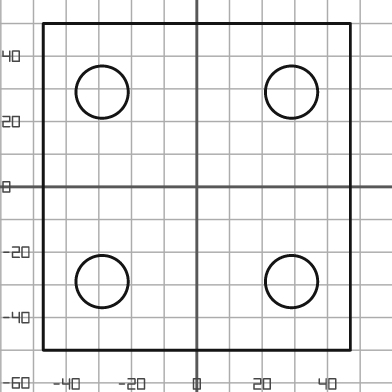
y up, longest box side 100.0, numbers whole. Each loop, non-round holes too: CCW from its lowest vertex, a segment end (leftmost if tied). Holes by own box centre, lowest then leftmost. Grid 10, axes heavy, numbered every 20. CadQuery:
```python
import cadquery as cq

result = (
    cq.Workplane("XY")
    .moveTo(-47.0, -50.0)
    .lineTo(47.0, -50.0)
    .lineTo(47.0, 50.0)
    .lineTo(-47.0, 50.0)
    .close()
    .moveTo(-29.0, -29.0)
    .circle(8.0)
    .moveTo(29.0, -29.0)
    .circle(8.0)
    .moveTo(-29.0, 29.0)
    .circle(8.0)
    .moveTo(29.0, 29.0)
    .circle(8.0)
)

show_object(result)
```